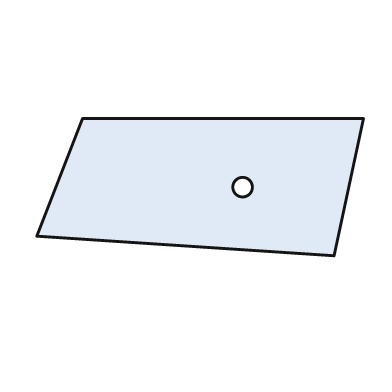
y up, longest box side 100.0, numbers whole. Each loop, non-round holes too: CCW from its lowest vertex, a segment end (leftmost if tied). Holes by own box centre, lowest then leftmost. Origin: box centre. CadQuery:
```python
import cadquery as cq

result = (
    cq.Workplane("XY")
    .moveTo(41.0, -21.0)
    .lineTo(50.0, 21.0)
    .lineTo(-36.0, 21.0)
    .lineTo(-50.0, -15.0)
    .close()
    .moveTo(13.0, 0.0)
    .circle(3.0)
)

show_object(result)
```